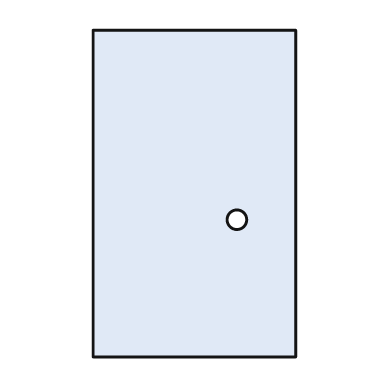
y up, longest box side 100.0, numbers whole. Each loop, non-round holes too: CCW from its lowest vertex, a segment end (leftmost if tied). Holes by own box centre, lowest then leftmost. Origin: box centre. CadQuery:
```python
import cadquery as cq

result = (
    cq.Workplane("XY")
    .moveTo(-31.0, -50.0)
    .lineTo(31.0, -50.0)
    .lineTo(31.0, 50.0)
    .lineTo(-31.0, 50.0)
    .close()
    .moveTo(13.0, -8.0)
    .circle(3.0)
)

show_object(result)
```